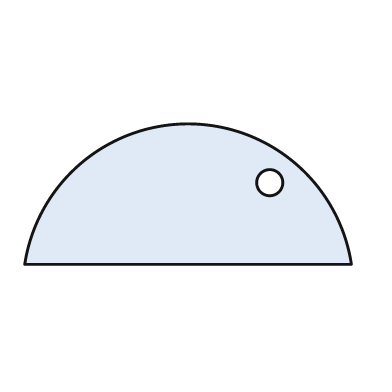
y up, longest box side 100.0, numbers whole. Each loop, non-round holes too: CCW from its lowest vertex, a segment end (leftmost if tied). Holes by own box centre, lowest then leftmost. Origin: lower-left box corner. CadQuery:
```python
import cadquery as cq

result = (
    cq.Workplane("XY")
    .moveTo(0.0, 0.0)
    .lineTo(100.0, 0.0)
    .threePointArc((50.0, 43.0), (0.0, 0.0))
    .close()
    .moveTo(75.0, 25.0)
    .circle(4.0)
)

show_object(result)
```